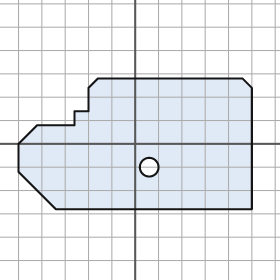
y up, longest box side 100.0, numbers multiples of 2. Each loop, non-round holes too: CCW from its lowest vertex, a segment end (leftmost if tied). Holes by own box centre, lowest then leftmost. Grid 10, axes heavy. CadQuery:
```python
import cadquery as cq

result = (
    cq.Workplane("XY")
    .moveTo(-34.0, -28.0)
    .lineTo(50.0, -28.0)
    .lineTo(50.0, 24.0)
    .lineTo(46.0, 28.0)
    .lineTo(-16.0, 28.0)
    .lineTo(-20.0, 24.0)
    .lineTo(-20.0, 14.0)
    .lineTo(-26.0, 14.0)
    .lineTo(-26.0, 8.0)
    .lineTo(-42.0, 8.0)
    .lineTo(-50.0, 0.0)
    .lineTo(-50.0, -12.0)
    .close()
    .moveTo(6.0, -10.0)
    .circle(4.0)
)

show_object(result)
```